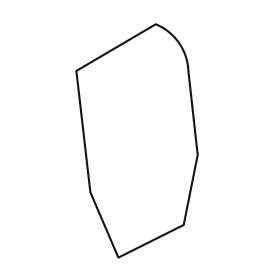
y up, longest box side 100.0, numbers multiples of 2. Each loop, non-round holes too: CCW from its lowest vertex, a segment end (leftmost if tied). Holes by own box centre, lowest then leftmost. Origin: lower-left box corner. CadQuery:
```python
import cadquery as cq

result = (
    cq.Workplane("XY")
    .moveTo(18.0, 0.0)
    .lineTo(46.0, 14.0)
    .lineTo(52.0, 44.0)
    .lineTo(48.0, 80.0)
    .threePointArc((44.0, 92.0), (34.0, 100.0))
    .lineTo(0.0, 80.0)
    .lineTo(6.0, 28.0)
    .close()
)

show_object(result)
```